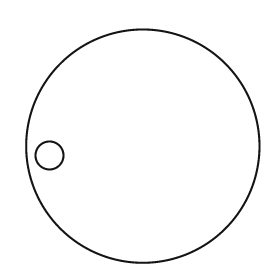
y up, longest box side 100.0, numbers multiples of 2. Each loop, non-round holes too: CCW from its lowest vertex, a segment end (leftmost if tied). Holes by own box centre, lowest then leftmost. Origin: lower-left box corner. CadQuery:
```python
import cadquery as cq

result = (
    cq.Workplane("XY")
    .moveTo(50.0, 50.0)
    .circle(50.0)
    .moveTo(10.0, 46.0)
    .circle(6.0)
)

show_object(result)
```